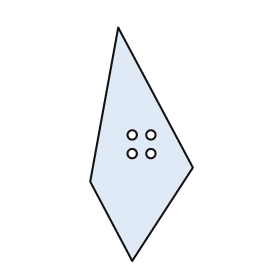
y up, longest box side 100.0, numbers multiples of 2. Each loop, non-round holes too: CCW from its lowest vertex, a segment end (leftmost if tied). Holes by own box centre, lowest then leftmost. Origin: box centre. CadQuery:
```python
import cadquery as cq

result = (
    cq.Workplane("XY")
    .moveTo(-4.0, -50.0)
    .lineTo(22.0, -10.0)
    .lineTo(-10.0, 50.0)
    .lineTo(-22.0, -16.0)
    .close()
    .moveTo(-4.0, -4.0)
    .circle(2.0)
    .moveTo(4.0, -4.0)
    .circle(2.0)
    .moveTo(-4.0, 4.0)
    .circle(2.0)
    .moveTo(4.0, 4.0)
    .circle(2.0)
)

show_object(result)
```